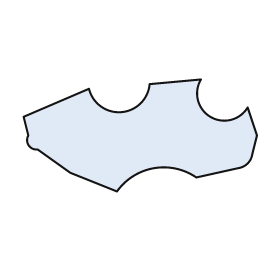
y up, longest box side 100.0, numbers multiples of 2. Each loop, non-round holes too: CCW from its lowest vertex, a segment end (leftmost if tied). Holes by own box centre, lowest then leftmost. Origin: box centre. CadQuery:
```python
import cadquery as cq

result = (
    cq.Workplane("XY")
    .moveTo(-10.0, -24.0)
    .threePointArc((6.0, -14.0), (24.0, -18.0))
    .lineTo(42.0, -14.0)
    .threePointArc((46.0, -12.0), (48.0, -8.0))
    .lineTo(50.0, 0.0)
    .lineTo(46.0, 12.0)
    .threePointArc((30.0, 8.0), (26.0, 24.0))
    .lineTo(4.0, 22.0)
    .threePointArc((-8.0, 10.0), (-22.0, 20.0))
    .lineTo(-50.0, 8.0)
    .lineTo(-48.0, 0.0)
    .threePointArc((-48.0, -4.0), (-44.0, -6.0))
    .lineTo(-30.0, -16.0)
    .close()
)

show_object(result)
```